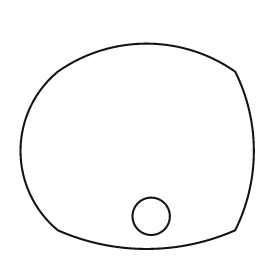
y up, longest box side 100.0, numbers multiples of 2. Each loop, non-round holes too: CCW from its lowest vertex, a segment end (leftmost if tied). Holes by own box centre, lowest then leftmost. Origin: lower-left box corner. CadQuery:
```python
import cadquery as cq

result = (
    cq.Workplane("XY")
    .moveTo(16.0, 8.0)
    .threePointArc((54.0, 0.0), (92.0, 8.0))
    .threePointArc((100.0, 42.0), (92.0, 76.0))
    .threePointArc((54.0, 88.0), (16.0, 76.0))
    .threePointArc((0.0, 42.0), (16.0, 8.0))
    .close()
    .moveTo(56.0, 14.0)
    .circle(8.0)
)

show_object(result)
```